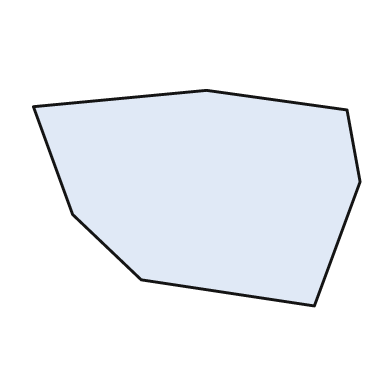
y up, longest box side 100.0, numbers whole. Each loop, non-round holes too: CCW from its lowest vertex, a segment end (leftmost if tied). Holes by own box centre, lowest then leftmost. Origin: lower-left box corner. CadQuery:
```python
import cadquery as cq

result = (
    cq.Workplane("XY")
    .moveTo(86.0, 0.0)
    .lineTo(100.0, 38.0)
    .lineTo(96.0, 60.0)
    .lineTo(53.0, 66.0)
    .lineTo(0.0, 61.0)
    .lineTo(12.0, 28.0)
    .lineTo(33.0, 8.0)
    .close()
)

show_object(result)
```